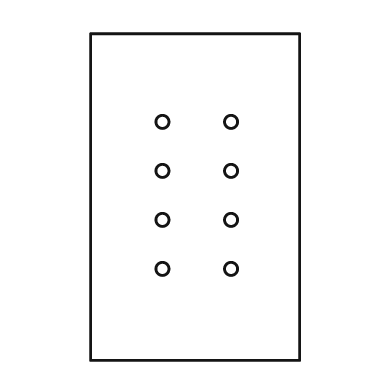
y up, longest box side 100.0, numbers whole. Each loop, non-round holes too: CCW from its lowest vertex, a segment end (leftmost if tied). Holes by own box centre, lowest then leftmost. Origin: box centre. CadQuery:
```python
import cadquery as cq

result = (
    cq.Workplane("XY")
    .moveTo(-32.0, -50.0)
    .lineTo(32.0, -50.0)
    .lineTo(32.0, 50.0)
    .lineTo(-32.0, 50.0)
    .close()
    .moveTo(-10.0, -22.0)
    .circle(2.0)
    .moveTo(11.0, -22.0)
    .circle(2.0)
    .moveTo(-10.0, -7.0)
    .circle(2.0)
    .moveTo(11.0, -7.0)
    .circle(2.0)
    .moveTo(-10.0, 8.0)
    .circle(2.0)
    .moveTo(11.0, 8.0)
    .circle(2.0)
    .moveTo(-10.0, 23.0)
    .circle(2.0)
    .moveTo(11.0, 23.0)
    .circle(2.0)
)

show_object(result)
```